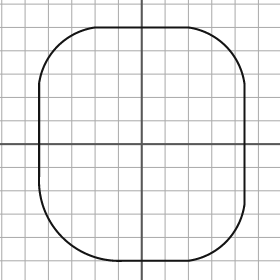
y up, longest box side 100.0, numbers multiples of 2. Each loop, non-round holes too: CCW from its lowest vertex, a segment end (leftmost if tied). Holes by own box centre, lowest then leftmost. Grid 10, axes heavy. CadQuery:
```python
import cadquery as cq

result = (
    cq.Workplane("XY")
    .moveTo(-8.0, -50.0)
    .lineTo(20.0, -50.0)
    .threePointArc((36.0, -42.0), (44.0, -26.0))
    .lineTo(44.0, 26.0)
    .threePointArc((36.0, 42.0), (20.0, 50.0))
    .lineTo(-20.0, 50.0)
    .threePointArc((-36.0, 42.0), (-44.0, 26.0))
    .lineTo(-44.0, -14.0)
    .threePointArc((-34.0, -40.0), (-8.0, -50.0))
    .close()
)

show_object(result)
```